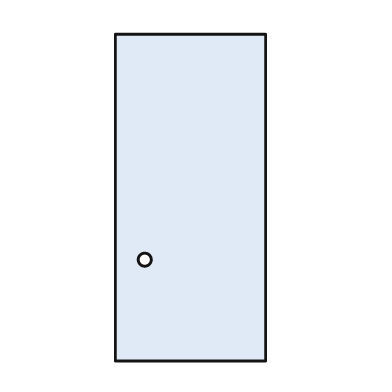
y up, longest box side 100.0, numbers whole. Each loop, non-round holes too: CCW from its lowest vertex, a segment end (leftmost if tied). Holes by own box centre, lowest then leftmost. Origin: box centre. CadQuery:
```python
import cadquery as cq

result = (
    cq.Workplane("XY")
    .moveTo(-23.0, -50.0)
    .lineTo(23.0, -50.0)
    .lineTo(23.0, 50.0)
    .lineTo(-23.0, 50.0)
    .close()
    .moveTo(-14.0, -19.0)
    .circle(2.0)
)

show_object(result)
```